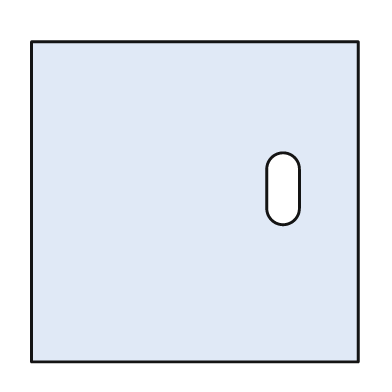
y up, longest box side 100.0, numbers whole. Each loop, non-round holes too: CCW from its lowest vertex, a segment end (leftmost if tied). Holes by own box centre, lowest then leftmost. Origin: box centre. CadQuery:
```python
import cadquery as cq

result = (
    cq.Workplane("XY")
    .moveTo(-50.0, -49.0)
    .lineTo(50.0, -49.0)
    .lineTo(50.0, 49.0)
    .lineTo(-50.0, 49.0)
    .close()
    .moveTo(22.0, -2.0)
    .threePointArc((27.0, -7.0), (32.0, -2.0))
    .lineTo(32.0, 10.0)
    .threePointArc((27.0, 15.0), (22.0, 10.0))
    .close()
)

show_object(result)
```